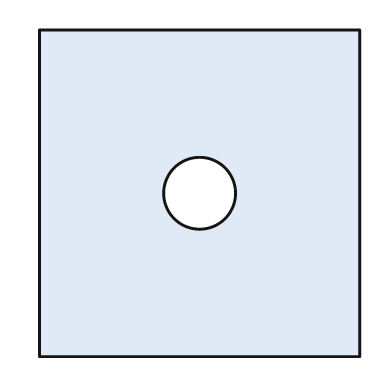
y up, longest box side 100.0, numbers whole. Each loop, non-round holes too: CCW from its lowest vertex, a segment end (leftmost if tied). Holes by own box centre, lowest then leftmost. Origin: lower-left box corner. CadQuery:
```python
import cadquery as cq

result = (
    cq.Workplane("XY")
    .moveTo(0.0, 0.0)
    .lineTo(98.0, 0.0)
    .lineTo(98.0, 100.0)
    .lineTo(0.0, 100.0)
    .close()
    .moveTo(49.0, 50.0)
    .circle(11.0)
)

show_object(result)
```